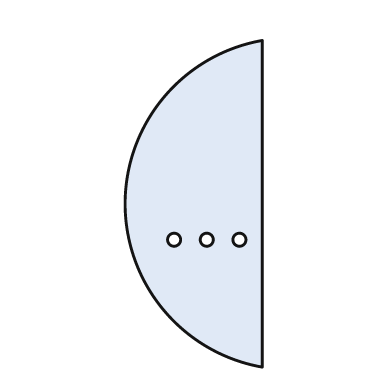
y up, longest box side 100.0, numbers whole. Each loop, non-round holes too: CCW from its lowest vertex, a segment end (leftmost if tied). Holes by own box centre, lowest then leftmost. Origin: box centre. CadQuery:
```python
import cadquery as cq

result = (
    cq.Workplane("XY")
    .moveTo(21.0, -50.0)
    .lineTo(21.0, 50.0)
    .threePointArc((-21.0, 0.0), (21.0, -50.0))
    .close()
    .moveTo(-6.0, -11.0)
    .circle(2.0)
    .moveTo(4.0, -11.0)
    .circle(2.0)
    .moveTo(14.0, -11.0)
    .circle(2.0)
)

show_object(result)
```